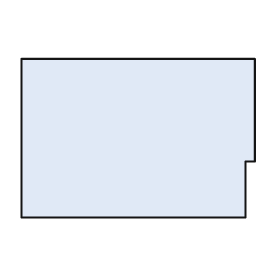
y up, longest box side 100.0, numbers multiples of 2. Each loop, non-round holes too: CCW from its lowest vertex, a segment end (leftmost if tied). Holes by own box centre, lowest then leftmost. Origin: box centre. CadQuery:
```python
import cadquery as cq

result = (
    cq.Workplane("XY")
    .moveTo(-50.0, -34.0)
    .lineTo(46.0, -34.0)
    .lineTo(46.0, -10.0)
    .lineTo(50.0, -10.0)
    .lineTo(50.0, 34.0)
    .lineTo(-50.0, 34.0)
    .close()
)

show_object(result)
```